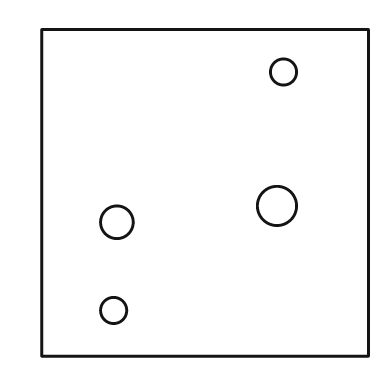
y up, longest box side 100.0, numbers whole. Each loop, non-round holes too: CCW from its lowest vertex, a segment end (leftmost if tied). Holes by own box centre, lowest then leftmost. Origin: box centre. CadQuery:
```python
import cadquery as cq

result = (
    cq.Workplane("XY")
    .moveTo(-50.0, -50.0)
    .lineTo(50.0, -50.0)
    .lineTo(50.0, 50.0)
    .lineTo(-50.0, 50.0)
    .close()
    .moveTo(-28.0, -36.0)
    .circle(4.0)
    .moveTo(-27.0, -9.0)
    .circle(5.0)
    .moveTo(22.0, -4.0)
    .circle(6.0)
    .moveTo(24.0, 37.0)
    .circle(4.0)
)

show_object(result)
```